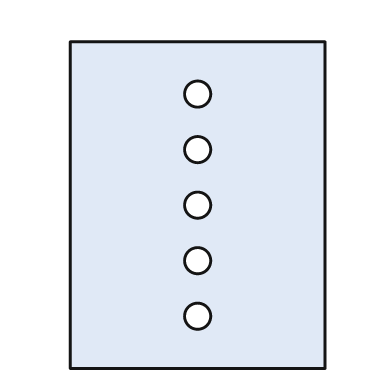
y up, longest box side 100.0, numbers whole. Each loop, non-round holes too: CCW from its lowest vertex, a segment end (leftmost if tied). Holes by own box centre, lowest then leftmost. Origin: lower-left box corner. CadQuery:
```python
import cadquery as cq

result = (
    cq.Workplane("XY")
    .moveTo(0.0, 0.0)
    .lineTo(78.0, 0.0)
    .lineTo(78.0, 100.0)
    .lineTo(0.0, 100.0)
    .close()
    .moveTo(39.0, 16.0)
    .circle(4.0)
    .moveTo(39.0, 33.0)
    .circle(4.0)
    .moveTo(39.0, 50.0)
    .circle(4.0)
    .moveTo(39.0, 67.0)
    .circle(4.0)
    .moveTo(39.0, 84.0)
    .circle(4.0)
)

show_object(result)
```